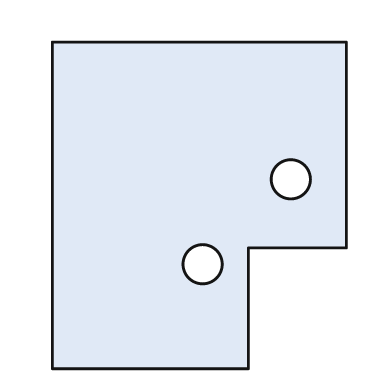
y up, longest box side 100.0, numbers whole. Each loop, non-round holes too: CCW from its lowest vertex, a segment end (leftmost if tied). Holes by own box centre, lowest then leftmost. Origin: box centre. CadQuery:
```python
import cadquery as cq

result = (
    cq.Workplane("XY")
    .moveTo(-45.0, -50.0)
    .lineTo(15.0, -50.0)
    .lineTo(15.0, -13.0)
    .lineTo(45.0, -13.0)
    .lineTo(45.0, 50.0)
    .lineTo(-45.0, 50.0)
    .close()
    .moveTo(1.0, -18.0)
    .circle(6.0)
    .moveTo(28.0, 8.0)
    .circle(6.0)
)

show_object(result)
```